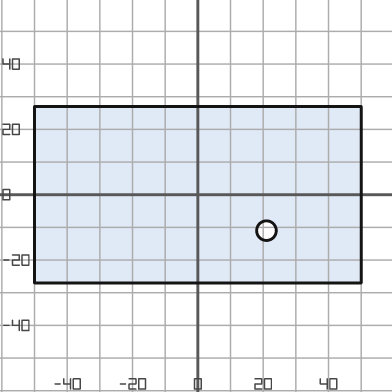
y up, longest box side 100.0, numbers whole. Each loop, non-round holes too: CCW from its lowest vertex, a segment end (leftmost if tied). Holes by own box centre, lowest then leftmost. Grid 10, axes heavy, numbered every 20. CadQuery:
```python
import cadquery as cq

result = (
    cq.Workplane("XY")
    .moveTo(-50.0, -27.0)
    .lineTo(50.0, -27.0)
    .lineTo(50.0, 27.0)
    .lineTo(-50.0, 27.0)
    .close()
    .moveTo(21.0, -11.0)
    .circle(3.0)
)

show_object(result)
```